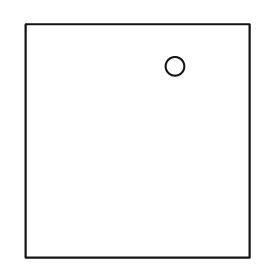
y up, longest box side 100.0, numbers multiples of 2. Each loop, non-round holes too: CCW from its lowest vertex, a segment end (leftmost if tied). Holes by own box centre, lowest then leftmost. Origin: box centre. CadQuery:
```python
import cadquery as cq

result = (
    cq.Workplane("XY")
    .moveTo(-48.0, -50.0)
    .lineTo(48.0, -50.0)
    .lineTo(48.0, 50.0)
    .lineTo(-48.0, 50.0)
    .close()
    .moveTo(16.0, 32.0)
    .circle(4.0)
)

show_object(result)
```